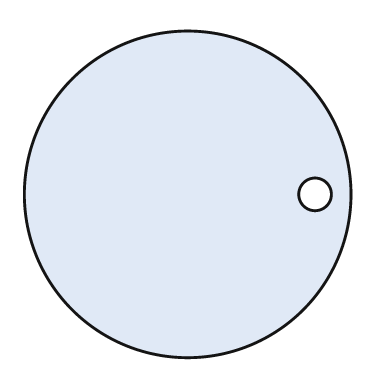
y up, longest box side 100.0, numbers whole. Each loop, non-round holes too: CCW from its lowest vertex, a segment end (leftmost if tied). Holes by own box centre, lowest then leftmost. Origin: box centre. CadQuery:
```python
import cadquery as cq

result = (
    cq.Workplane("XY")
    .moveTo(0.0, 0.0)
    .circle(50.0)
    .moveTo(39.0, 0.0)
    .circle(5.0)
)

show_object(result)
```